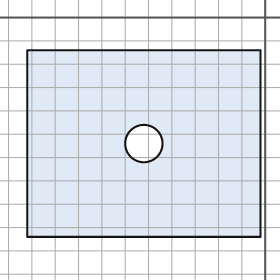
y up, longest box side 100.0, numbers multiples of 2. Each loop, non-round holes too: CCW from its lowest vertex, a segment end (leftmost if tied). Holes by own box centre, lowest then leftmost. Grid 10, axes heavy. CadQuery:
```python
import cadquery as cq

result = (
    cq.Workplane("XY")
    .moveTo(-102.0, -94.0)
    .lineTo(-2.0, -94.0)
    .lineTo(-2.0, -14.0)
    .lineTo(-102.0, -14.0)
    .close()
    .moveTo(-52.0, -54.0)
    .circle(8.0)
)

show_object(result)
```